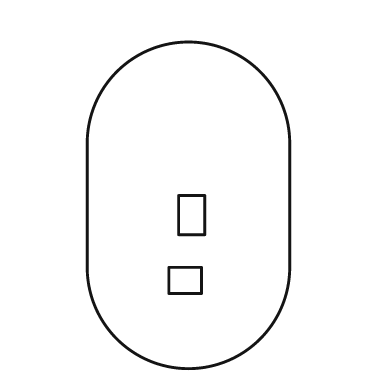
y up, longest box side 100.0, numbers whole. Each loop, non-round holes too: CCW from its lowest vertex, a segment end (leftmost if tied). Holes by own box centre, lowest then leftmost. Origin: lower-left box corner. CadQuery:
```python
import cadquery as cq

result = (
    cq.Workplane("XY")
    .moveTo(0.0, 31.0)
    .threePointArc((31.0, 0.0), (62.0, 31.0))
    .lineTo(62.0, 69.0)
    .threePointArc((31.0, 100.0), (0.0, 69.0))
    .close()
    .moveTo(25.0, 23.0)
    .lineTo(35.0, 23.0)
    .lineTo(35.0, 31.0)
    .lineTo(25.0, 31.0)
    .close()
    .moveTo(28.0, 41.0)
    .lineTo(36.0, 41.0)
    .lineTo(36.0, 53.0)
    .lineTo(28.0, 53.0)
    .close()
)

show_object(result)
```